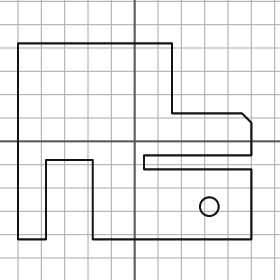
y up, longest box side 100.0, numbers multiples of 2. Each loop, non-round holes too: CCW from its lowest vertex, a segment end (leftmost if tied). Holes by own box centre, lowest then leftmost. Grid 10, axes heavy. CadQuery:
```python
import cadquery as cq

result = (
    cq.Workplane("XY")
    .moveTo(-50.0, -42.0)
    .lineTo(-38.0, -42.0)
    .lineTo(-38.0, -8.0)
    .lineTo(-18.0, -8.0)
    .lineTo(-18.0, -42.0)
    .lineTo(50.0, -42.0)
    .lineTo(50.0, -12.0)
    .lineTo(4.0, -12.0)
    .lineTo(4.0, -6.0)
    .lineTo(50.0, -6.0)
    .lineTo(50.0, 8.0)
    .lineTo(46.0, 12.0)
    .lineTo(16.0, 12.0)
    .lineTo(16.0, 42.0)
    .lineTo(-50.0, 42.0)
    .close()
    .moveTo(32.0, -28.0)
    .circle(4.0)
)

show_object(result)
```